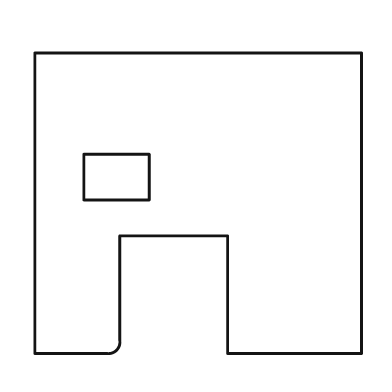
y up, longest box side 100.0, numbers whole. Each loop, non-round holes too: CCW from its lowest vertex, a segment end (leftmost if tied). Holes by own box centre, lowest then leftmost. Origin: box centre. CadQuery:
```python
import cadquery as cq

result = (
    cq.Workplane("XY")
    .moveTo(-50.0, -46.0)
    .lineTo(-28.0, -46.0)
    .threePointArc((-25.0, -45.0), (-24.0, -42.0))
    .lineTo(-24.0, -10.0)
    .lineTo(9.0, -10.0)
    .lineTo(9.0, -46.0)
    .lineTo(50.0, -46.0)
    .lineTo(50.0, 46.0)
    .lineTo(-50.0, 46.0)
    .close()
    .moveTo(-35.0, 1.0)
    .lineTo(-15.0, 1.0)
    .lineTo(-15.0, 15.0)
    .lineTo(-35.0, 15.0)
    .close()
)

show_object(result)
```